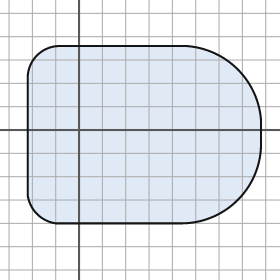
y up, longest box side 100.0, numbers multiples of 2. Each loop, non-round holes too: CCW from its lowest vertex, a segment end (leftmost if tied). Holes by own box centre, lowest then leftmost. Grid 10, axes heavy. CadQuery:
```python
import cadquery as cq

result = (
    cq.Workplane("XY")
    .moveTo(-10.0, -40.0)
    .lineTo(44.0, -40.0)
    .threePointArc((68.0, -30.0), (78.0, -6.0))
    .lineTo(78.0, 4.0)
    .threePointArc((68.0, 26.0), (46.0, 36.0))
    .lineTo(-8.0, 36.0)
    .threePointArc((-18.0, 32.0), (-22.0, 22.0))
    .lineTo(-22.0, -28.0)
    .threePointArc((-18.0, -36.0), (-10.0, -40.0))
    .close()
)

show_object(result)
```